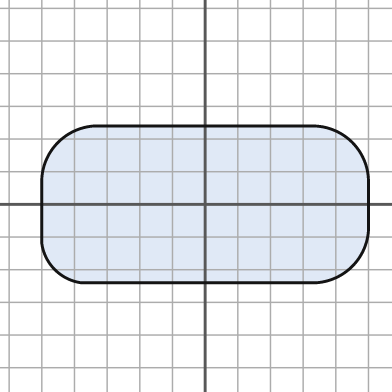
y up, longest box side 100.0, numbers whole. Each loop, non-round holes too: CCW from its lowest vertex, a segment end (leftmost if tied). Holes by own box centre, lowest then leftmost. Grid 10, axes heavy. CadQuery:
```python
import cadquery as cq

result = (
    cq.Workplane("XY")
    .moveTo(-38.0, -24.0)
    .lineTo(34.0, -24.0)
    .threePointArc((45.0, -19.0), (50.0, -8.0))
    .lineTo(50.0, 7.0)
    .threePointArc((45.0, 19.0), (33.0, 24.0))
    .lineTo(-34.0, 24.0)
    .threePointArc((-45.0, 19.0), (-50.0, 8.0))
    .lineTo(-50.0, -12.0)
    .threePointArc((-46.0, -20.0), (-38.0, -24.0))
    .close()
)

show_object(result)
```